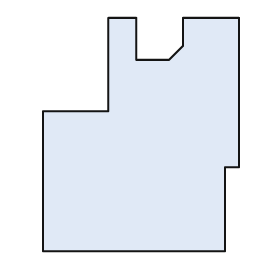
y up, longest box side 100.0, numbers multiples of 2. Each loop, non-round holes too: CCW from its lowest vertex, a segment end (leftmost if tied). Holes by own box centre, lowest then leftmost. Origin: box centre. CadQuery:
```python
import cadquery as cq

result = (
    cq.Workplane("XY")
    .moveTo(-42.0, -50.0)
    .lineTo(36.0, -50.0)
    .lineTo(36.0, -14.0)
    .lineTo(42.0, -14.0)
    .lineTo(42.0, 50.0)
    .lineTo(18.0, 50.0)
    .lineTo(18.0, 38.0)
    .lineTo(12.0, 32.0)
    .lineTo(-2.0, 32.0)
    .lineTo(-2.0, 50.0)
    .lineTo(-14.0, 50.0)
    .lineTo(-14.0, 10.0)
    .lineTo(-42.0, 10.0)
    .close()
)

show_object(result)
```